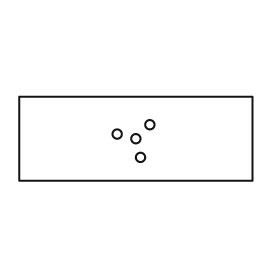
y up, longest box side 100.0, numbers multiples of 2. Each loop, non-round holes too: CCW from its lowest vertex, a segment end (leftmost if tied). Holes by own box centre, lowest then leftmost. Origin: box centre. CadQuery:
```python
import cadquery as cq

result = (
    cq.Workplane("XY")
    .moveTo(-50.0, -18.0)
    .lineTo(50.0, -18.0)
    .lineTo(50.0, 18.0)
    .lineTo(-50.0, 18.0)
    .close()
    .moveTo(2.0, -8.0)
    .circle(2.0)
    .moveTo(0.0, 0.0)
    .circle(2.0)
    .moveTo(-8.0, 2.0)
    .circle(2.0)
    .moveTo(6.0, 6.0)
    .circle(2.0)
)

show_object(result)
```